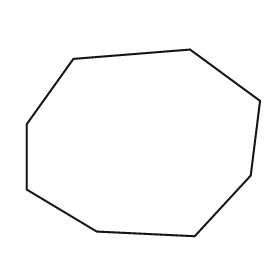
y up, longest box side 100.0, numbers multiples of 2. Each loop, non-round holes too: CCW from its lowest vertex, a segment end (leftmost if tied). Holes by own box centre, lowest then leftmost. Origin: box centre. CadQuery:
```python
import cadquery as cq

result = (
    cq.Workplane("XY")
    .moveTo(22.0, -40.0)
    .lineTo(46.0, -14.0)
    .lineTo(50.0, 18.0)
    .lineTo(20.0, 40.0)
    .lineTo(-30.0, 36.0)
    .lineTo(-50.0, 8.0)
    .lineTo(-50.0, -20.0)
    .lineTo(-20.0, -38.0)
    .close()
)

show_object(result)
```